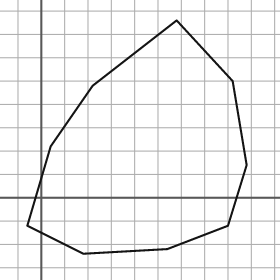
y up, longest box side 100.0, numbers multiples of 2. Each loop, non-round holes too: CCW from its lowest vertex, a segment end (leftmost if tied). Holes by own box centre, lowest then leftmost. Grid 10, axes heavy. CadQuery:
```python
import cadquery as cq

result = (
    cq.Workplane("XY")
    .moveTo(18.0, -24.0)
    .lineTo(54.0, -22.0)
    .lineTo(80.0, -12.0)
    .lineTo(88.0, 14.0)
    .lineTo(82.0, 50.0)
    .lineTo(58.0, 76.0)
    .lineTo(22.0, 48.0)
    .lineTo(4.0, 22.0)
    .lineTo(-6.0, -12.0)
    .close()
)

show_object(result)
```